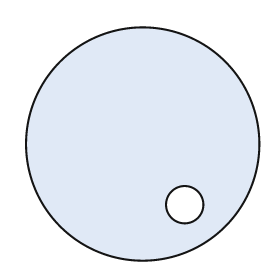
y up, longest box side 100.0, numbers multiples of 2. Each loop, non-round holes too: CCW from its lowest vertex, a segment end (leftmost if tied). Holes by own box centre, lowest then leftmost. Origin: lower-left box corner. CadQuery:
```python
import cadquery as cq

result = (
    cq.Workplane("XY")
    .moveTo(50.0, 50.0)
    .circle(50.0)
    .moveTo(68.0, 24.0)
    .circle(8.0)
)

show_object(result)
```